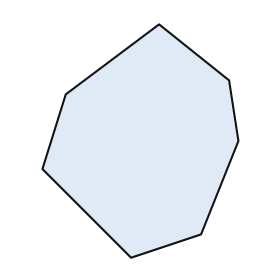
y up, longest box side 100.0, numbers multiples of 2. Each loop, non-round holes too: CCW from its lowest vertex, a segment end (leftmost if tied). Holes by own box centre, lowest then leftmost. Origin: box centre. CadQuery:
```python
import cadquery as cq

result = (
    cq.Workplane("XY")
    .moveTo(-4.0, -50.0)
    .lineTo(26.0, -40.0)
    .lineTo(42.0, 0.0)
    .lineTo(38.0, 26.0)
    .lineTo(8.0, 50.0)
    .lineTo(-32.0, 20.0)
    .lineTo(-42.0, -12.0)
    .close()
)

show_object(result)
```